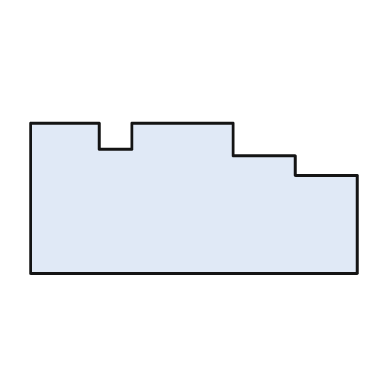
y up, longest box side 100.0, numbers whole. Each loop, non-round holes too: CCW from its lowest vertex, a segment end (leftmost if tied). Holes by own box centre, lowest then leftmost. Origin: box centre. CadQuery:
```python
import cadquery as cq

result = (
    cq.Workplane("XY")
    .moveTo(-50.0, -23.0)
    .lineTo(50.0, -23.0)
    .lineTo(50.0, 7.0)
    .lineTo(31.0, 7.0)
    .lineTo(31.0, 13.0)
    .lineTo(12.0, 13.0)
    .lineTo(12.0, 23.0)
    .lineTo(-19.0, 23.0)
    .lineTo(-19.0, 15.0)
    .lineTo(-29.0, 15.0)
    .lineTo(-29.0, 23.0)
    .lineTo(-50.0, 23.0)
    .close()
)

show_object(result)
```